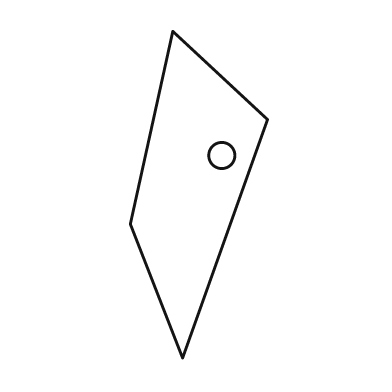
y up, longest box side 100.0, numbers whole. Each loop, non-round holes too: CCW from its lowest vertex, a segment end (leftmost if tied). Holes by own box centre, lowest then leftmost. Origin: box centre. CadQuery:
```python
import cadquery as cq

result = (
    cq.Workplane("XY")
    .moveTo(-5.0, -50.0)
    .lineTo(21.0, 23.0)
    .lineTo(-8.0, 50.0)
    .lineTo(-21.0, -9.0)
    .close()
    .moveTo(7.0, 12.0)
    .circle(4.0)
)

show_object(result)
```